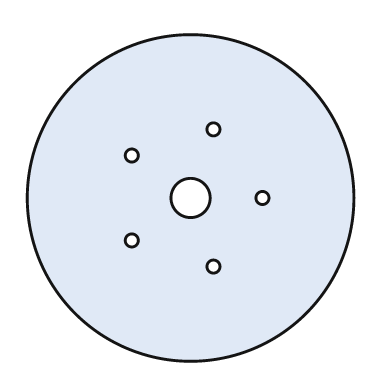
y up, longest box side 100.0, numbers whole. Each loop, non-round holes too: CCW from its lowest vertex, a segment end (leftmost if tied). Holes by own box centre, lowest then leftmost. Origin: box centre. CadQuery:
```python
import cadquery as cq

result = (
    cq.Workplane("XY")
    .moveTo(0.0, 0.0)
    .circle(50.0)
    .moveTo(7.0, -21.0)
    .circle(2.0)
    .moveTo(-18.0, -13.0)
    .circle(2.0)
    .moveTo(0.0, 0.0)
    .circle(6.0)
    .moveTo(22.0, 0.0)
    .circle(2.0)
    .moveTo(-18.0, 13.0)
    .circle(2.0)
    .moveTo(7.0, 21.0)
    .circle(2.0)
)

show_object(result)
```